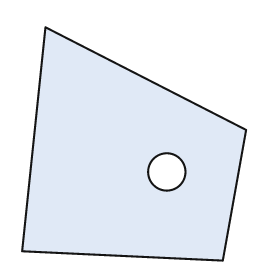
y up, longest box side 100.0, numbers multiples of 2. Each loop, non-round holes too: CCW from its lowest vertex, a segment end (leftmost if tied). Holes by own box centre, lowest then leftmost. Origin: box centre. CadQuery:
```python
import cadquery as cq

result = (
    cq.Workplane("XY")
    .moveTo(38.0, -50.0)
    .lineTo(48.0, 6.0)
    .lineTo(-38.0, 50.0)
    .lineTo(-48.0, -46.0)
    .close()
    .moveTo(14.0, -12.0)
    .circle(8.0)
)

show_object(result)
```